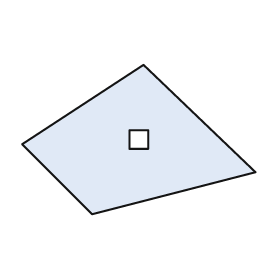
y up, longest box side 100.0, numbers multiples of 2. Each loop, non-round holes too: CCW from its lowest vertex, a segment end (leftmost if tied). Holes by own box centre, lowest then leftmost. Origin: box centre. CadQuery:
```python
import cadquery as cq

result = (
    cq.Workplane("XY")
    .moveTo(-20.0, -32.0)
    .lineTo(50.0, -14.0)
    .lineTo(2.0, 32.0)
    .lineTo(-50.0, -2.0)
    .close()
    .moveTo(-4.0, -4.0)
    .lineTo(4.0, -4.0)
    .lineTo(4.0, 4.0)
    .lineTo(-4.0, 4.0)
    .close()
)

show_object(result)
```